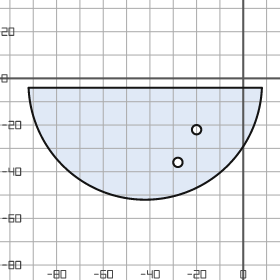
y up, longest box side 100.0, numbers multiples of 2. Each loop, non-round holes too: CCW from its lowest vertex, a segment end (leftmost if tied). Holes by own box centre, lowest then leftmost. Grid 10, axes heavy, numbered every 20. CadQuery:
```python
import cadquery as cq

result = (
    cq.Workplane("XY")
    .moveTo(-92.0, -4.0)
    .threePointArc((-42.0, -52.0), (8.0, -4.0))
    .close()
    .moveTo(-28.0, -36.0)
    .circle(2.0)
    .moveTo(-20.0, -22.0)
    .circle(2.0)
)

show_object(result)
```